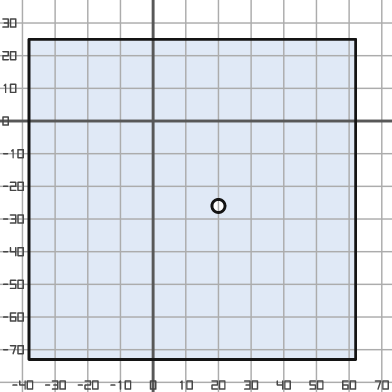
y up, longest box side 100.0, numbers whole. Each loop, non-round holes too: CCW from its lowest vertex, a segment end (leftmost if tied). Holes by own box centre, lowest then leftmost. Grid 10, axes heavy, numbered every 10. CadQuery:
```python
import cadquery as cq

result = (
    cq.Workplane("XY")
    .moveTo(-38.0, -73.0)
    .lineTo(62.0, -73.0)
    .lineTo(62.0, 25.0)
    .lineTo(-38.0, 25.0)
    .close()
    .moveTo(20.0, -26.0)
    .circle(2.0)
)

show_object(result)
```